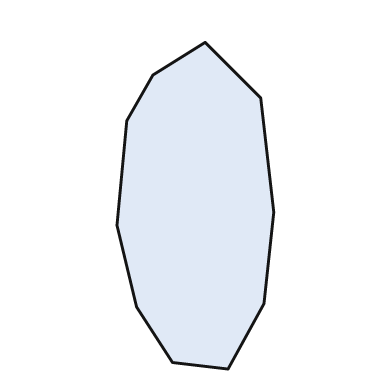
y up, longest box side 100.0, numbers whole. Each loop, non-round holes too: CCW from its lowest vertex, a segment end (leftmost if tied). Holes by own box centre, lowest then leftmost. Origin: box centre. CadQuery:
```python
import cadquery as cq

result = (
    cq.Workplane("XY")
    .moveTo(10.0, -50.0)
    .lineTo(21.0, -30.0)
    .lineTo(24.0, -2.0)
    .lineTo(20.0, 33.0)
    .lineTo(3.0, 50.0)
    .lineTo(-13.0, 40.0)
    .lineTo(-21.0, 26.0)
    .lineTo(-24.0, -6.0)
    .lineTo(-18.0, -31.0)
    .lineTo(-7.0, -48.0)
    .close()
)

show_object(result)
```